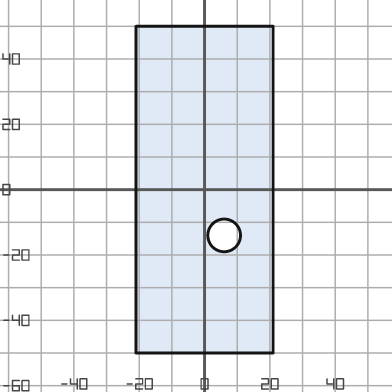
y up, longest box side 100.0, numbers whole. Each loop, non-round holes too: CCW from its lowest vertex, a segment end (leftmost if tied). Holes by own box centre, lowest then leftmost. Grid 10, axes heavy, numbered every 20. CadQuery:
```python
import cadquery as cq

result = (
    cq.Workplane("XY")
    .moveTo(-21.0, -50.0)
    .lineTo(21.0, -50.0)
    .lineTo(21.0, 50.0)
    .lineTo(-21.0, 50.0)
    .close()
    .moveTo(6.0, -14.0)
    .circle(5.0)
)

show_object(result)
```